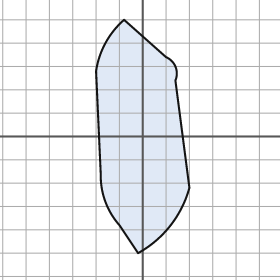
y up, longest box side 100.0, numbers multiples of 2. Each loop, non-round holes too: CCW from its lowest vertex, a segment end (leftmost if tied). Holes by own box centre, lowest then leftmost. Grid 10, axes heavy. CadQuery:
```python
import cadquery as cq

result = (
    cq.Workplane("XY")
    .moveTo(-2.0, -50.0)
    .threePointArc((12.0, -38.0), (20.0, -22.0))
    .lineTo(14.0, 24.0)
    .threePointArc((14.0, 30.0), (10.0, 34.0))
    .lineTo(-8.0, 50.0)
    .threePointArc((-16.0, 40.0), (-20.0, 28.0))
    .lineTo(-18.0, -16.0)
    .threePointArc((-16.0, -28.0), (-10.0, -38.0))
    .close()
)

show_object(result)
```